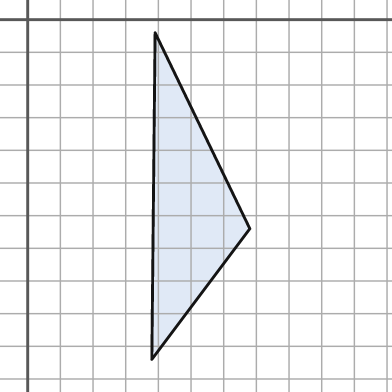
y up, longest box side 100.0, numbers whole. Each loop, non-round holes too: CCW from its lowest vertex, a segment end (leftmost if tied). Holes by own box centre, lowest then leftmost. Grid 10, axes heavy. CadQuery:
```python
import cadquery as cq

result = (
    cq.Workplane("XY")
    .moveTo(38.0, -104.0)
    .lineTo(68.0, -64.0)
    .lineTo(39.0, -4.0)
    .close()
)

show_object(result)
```